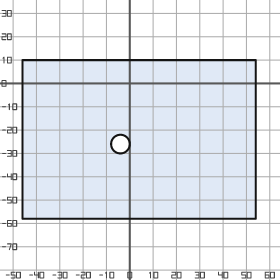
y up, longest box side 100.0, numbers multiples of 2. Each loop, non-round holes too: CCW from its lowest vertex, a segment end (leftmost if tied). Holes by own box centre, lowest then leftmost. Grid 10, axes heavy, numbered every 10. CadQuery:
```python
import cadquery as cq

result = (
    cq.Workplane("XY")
    .moveTo(-46.0, -58.0)
    .lineTo(54.0, -58.0)
    .lineTo(54.0, 10.0)
    .lineTo(-46.0, 10.0)
    .close()
    .moveTo(-4.0, -26.0)
    .circle(4.0)
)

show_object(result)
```